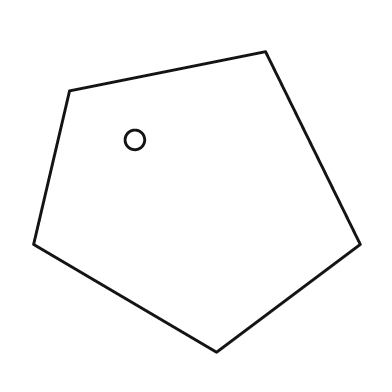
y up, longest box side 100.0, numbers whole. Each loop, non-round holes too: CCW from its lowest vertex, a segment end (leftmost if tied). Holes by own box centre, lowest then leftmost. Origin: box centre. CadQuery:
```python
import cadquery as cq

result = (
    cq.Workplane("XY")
    .moveTo(6.0, -46.0)
    .lineTo(50.0, -13.0)
    .lineTo(21.0, 46.0)
    .lineTo(-39.0, 34.0)
    .lineTo(-50.0, -13.0)
    .close()
    .moveTo(-19.0, 19.0)
    .circle(3.0)
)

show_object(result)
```